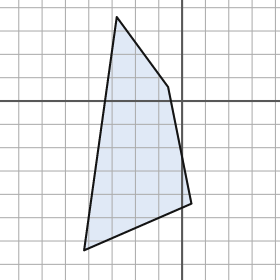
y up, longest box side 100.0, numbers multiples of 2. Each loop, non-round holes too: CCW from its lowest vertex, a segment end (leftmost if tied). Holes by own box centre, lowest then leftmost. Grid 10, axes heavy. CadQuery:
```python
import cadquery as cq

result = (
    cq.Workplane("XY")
    .moveTo(-42.0, -64.0)
    .lineTo(4.0, -44.0)
    .lineTo(-6.0, 6.0)
    .lineTo(-28.0, 36.0)
    .close()
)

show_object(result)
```